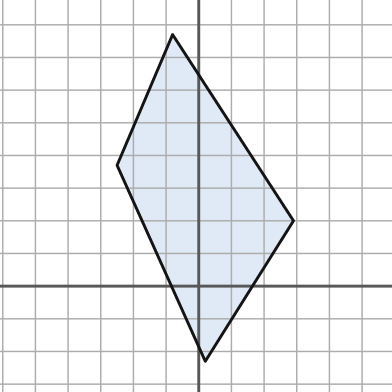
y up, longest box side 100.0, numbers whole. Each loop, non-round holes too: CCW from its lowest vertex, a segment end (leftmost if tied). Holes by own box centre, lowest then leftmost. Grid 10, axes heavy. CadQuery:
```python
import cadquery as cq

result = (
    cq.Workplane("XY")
    .moveTo(2.0, -23.0)
    .lineTo(29.0, 20.0)
    .lineTo(-8.0, 77.0)
    .lineTo(-25.0, 37.0)
    .close()
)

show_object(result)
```